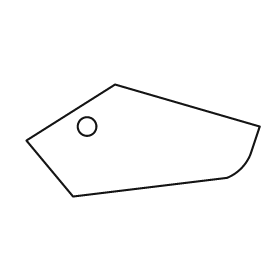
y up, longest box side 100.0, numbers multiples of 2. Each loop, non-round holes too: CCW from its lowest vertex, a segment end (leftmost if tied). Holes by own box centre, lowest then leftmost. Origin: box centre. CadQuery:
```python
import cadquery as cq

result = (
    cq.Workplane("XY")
    .moveTo(-30.0, -24.0)
    .lineTo(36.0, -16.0)
    .threePointArc((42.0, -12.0), (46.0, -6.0))
    .lineTo(50.0, 6.0)
    .lineTo(-12.0, 24.0)
    .lineTo(-50.0, 0.0)
    .close()
    .moveTo(-24.0, 6.0)
    .circle(4.0)
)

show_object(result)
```